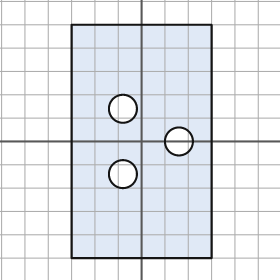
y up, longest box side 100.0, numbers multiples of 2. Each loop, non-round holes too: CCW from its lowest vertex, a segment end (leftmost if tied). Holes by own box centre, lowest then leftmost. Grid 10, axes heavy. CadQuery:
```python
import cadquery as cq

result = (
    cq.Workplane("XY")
    .moveTo(-30.0, -50.0)
    .lineTo(30.0, -50.0)
    .lineTo(30.0, 50.0)
    .lineTo(-30.0, 50.0)
    .close()
    .moveTo(-8.0, -14.0)
    .circle(6.0)
    .moveTo(16.0, 0.0)
    .circle(6.0)
    .moveTo(-8.0, 14.0)
    .circle(6.0)
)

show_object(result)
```